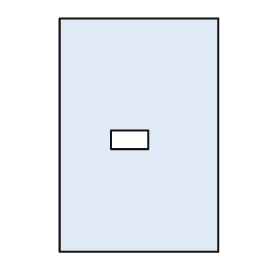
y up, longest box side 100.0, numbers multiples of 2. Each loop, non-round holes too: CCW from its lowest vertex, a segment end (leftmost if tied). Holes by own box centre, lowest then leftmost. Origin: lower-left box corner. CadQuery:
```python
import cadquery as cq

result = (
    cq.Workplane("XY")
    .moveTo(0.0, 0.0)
    .lineTo(68.0, 0.0)
    .lineTo(68.0, 100.0)
    .lineTo(0.0, 100.0)
    .close()
    .moveTo(22.0, 44.0)
    .lineTo(38.0, 44.0)
    .lineTo(38.0, 52.0)
    .lineTo(22.0, 52.0)
    .close()
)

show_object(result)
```